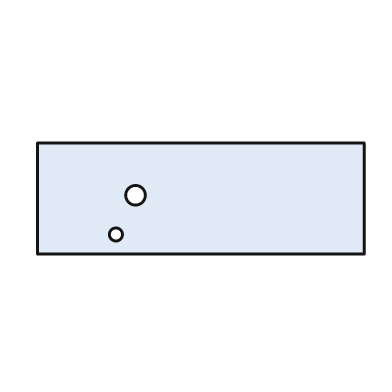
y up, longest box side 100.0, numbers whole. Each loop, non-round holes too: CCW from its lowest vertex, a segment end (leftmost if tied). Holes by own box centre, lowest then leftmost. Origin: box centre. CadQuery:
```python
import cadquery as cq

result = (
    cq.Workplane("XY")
    .moveTo(-50.0, -17.0)
    .lineTo(50.0, -17.0)
    .lineTo(50.0, 17.0)
    .lineTo(-50.0, 17.0)
    .close()
    .moveTo(-26.0, -11.0)
    .circle(2.0)
    .moveTo(-20.0, 1.0)
    .circle(3.0)
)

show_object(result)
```